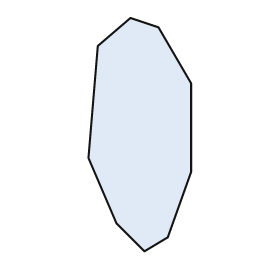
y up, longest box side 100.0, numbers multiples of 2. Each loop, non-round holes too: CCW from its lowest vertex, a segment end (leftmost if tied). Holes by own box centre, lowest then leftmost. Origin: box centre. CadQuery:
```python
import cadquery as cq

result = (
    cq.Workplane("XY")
    .moveTo(2.0, -50.0)
    .lineTo(12.0, -44.0)
    .lineTo(22.0, -16.0)
    .lineTo(22.0, 22.0)
    .lineTo(8.0, 46.0)
    .lineTo(-4.0, 50.0)
    .lineTo(-18.0, 38.0)
    .lineTo(-22.0, -10.0)
    .lineTo(-10.0, -38.0)
    .close()
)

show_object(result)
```